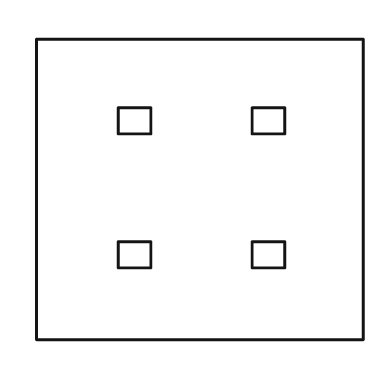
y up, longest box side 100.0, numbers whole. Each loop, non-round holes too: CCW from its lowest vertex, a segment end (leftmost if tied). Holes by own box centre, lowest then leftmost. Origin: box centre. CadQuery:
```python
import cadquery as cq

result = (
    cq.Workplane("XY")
    .moveTo(-50.0, -46.0)
    .lineTo(50.0, -46.0)
    .lineTo(50.0, 46.0)
    .lineTo(-50.0, 46.0)
    .close()
    .moveTo(-25.0, -24.0)
    .lineTo(-15.0, -24.0)
    .lineTo(-15.0, -16.0)
    .lineTo(-25.0, -16.0)
    .close()
    .moveTo(16.0, -24.0)
    .lineTo(26.0, -24.0)
    .lineTo(26.0, -16.0)
    .lineTo(16.0, -16.0)
    .close()
    .moveTo(-25.0, 17.0)
    .lineTo(-15.0, 17.0)
    .lineTo(-15.0, 25.0)
    .lineTo(-25.0, 25.0)
    .close()
    .moveTo(16.0, 17.0)
    .lineTo(26.0, 17.0)
    .lineTo(26.0, 25.0)
    .lineTo(16.0, 25.0)
    .close()
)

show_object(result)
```